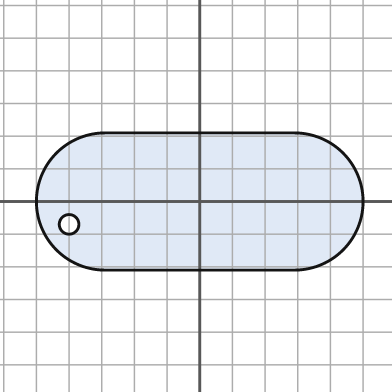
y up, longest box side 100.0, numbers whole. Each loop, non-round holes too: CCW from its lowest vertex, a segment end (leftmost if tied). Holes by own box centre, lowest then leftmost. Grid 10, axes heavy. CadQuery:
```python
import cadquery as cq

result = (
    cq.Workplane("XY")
    .moveTo(-29.0, -21.0)
    .lineTo(29.0, -21.0)
    .threePointArc((50.0, 0.0), (29.0, 21.0))
    .lineTo(-29.0, 21.0)
    .threePointArc((-50.0, 0.0), (-29.0, -21.0))
    .close()
    .moveTo(-40.0, -7.0)
    .circle(3.0)
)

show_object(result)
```